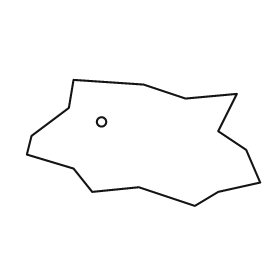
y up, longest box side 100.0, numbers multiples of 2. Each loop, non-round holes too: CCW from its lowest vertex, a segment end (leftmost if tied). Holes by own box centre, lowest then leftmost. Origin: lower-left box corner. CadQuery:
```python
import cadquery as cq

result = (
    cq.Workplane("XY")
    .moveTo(72.0, 0.0)
    .lineTo(82.0, 6.0)
    .lineTo(100.0, 10.0)
    .lineTo(94.0, 24.0)
    .lineTo(82.0, 32.0)
    .lineTo(90.0, 48.0)
    .lineTo(68.0, 46.0)
    .lineTo(50.0, 52.0)
    .lineTo(20.0, 54.0)
    .lineTo(18.0, 42.0)
    .lineTo(2.0, 30.0)
    .lineTo(0.0, 22.0)
    .lineTo(20.0, 16.0)
    .lineTo(28.0, 6.0)
    .lineTo(48.0, 8.0)
    .close()
    .moveTo(32.0, 36.0)
    .circle(2.0)
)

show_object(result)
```